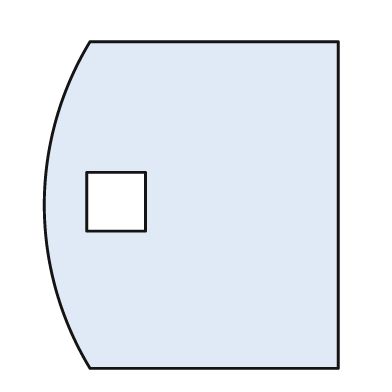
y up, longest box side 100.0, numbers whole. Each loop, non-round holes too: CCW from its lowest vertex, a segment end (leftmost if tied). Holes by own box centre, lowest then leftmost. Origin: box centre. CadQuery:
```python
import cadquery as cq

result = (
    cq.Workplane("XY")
    .moveTo(-31.0, -50.0)
    .lineTo(45.0, -50.0)
    .lineTo(45.0, 50.0)
    .lineTo(-31.0, 50.0)
    .threePointArc((-45.0, 0.0), (-31.0, -50.0))
    .close()
    .moveTo(-32.0, -8.0)
    .lineTo(-14.0, -8.0)
    .lineTo(-14.0, 10.0)
    .lineTo(-32.0, 10.0)
    .close()
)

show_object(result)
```